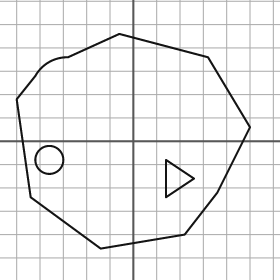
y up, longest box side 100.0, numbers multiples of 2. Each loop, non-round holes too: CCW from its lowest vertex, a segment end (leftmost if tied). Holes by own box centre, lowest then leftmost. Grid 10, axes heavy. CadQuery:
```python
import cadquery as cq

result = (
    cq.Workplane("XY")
    .moveTo(-14.0, -46.0)
    .lineTo(22.0, -40.0)
    .lineTo(36.0, -22.0)
    .lineTo(50.0, 6.0)
    .lineTo(32.0, 36.0)
    .lineTo(-6.0, 46.0)
    .lineTo(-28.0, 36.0)
    .threePointArc((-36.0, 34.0), (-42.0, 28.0))
    .lineTo(-50.0, 18.0)
    .lineTo(-44.0, -24.0)
    .close()
    .moveTo(14.0, -24.0)
    .lineTo(26.0, -16.0)
    .lineTo(14.0, -8.0)
    .close()
    .moveTo(-36.0, -8.0)
    .circle(6.0)
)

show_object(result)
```